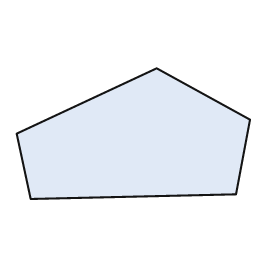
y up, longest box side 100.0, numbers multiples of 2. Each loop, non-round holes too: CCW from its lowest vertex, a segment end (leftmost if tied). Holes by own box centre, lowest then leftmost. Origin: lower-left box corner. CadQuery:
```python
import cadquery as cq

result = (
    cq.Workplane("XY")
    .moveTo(6.0, 0.0)
    .lineTo(94.0, 2.0)
    .lineTo(100.0, 34.0)
    .lineTo(60.0, 56.0)
    .lineTo(0.0, 28.0)
    .close()
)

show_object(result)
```